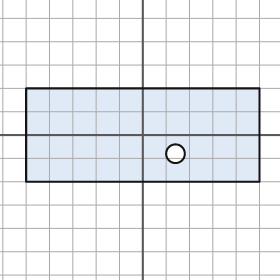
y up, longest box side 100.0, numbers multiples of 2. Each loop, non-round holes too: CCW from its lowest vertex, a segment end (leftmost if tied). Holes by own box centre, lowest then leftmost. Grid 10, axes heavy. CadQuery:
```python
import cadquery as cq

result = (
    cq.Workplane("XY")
    .moveTo(-50.0, -20.0)
    .lineTo(50.0, -20.0)
    .lineTo(50.0, 20.0)
    .lineTo(-50.0, 20.0)
    .close()
    .moveTo(14.0, -8.0)
    .circle(4.0)
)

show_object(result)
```